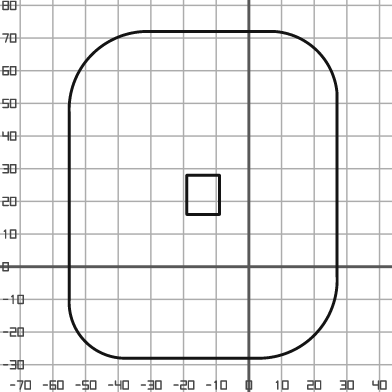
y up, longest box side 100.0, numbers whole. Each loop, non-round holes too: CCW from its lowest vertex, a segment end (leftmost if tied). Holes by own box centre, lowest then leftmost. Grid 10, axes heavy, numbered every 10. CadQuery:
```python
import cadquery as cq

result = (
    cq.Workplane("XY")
    .moveTo(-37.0, -28.0)
    .lineTo(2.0, -28.0)
    .threePointArc((20.0, -21.0), (27.0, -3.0))
    .lineTo(27.0, 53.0)
    .threePointArc((21.0, 66.0), (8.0, 72.0))
    .lineTo(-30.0, 72.0)
    .threePointArc((-48.0, 65.0), (-55.0, 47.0))
    .lineTo(-55.0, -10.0)
    .threePointArc((-50.0, -23.0), (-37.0, -28.0))
    .close()
    .moveTo(-19.0, 16.0)
    .lineTo(-9.0, 16.0)
    .lineTo(-9.0, 28.0)
    .lineTo(-19.0, 28.0)
    .close()
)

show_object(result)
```